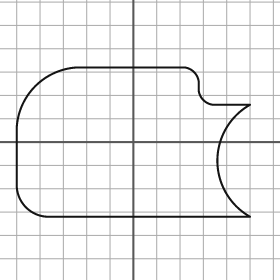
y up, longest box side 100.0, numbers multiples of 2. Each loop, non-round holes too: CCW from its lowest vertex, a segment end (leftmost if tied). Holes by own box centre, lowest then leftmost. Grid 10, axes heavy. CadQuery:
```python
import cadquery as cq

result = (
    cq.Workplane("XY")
    .moveTo(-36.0, -32.0)
    .lineTo(50.0, -32.0)
    .threePointArc((36.0, -8.0), (50.0, 16.0))
    .lineTo(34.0, 16.0)
    .threePointArc((30.0, 18.0), (28.0, 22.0))
    .lineTo(28.0, 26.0)
    .threePointArc((26.0, 30.0), (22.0, 32.0))
    .lineTo(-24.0, 32.0)
    .threePointArc((-42.0, 24.0), (-50.0, 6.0))
    .lineTo(-50.0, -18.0)
    .threePointArc((-46.0, -28.0), (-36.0, -32.0))
    .close()
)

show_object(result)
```